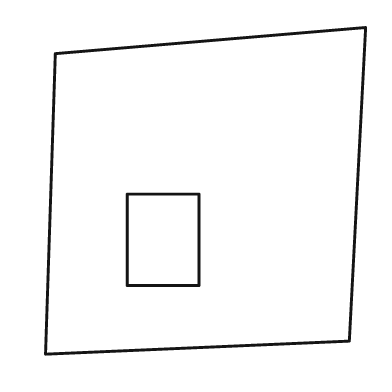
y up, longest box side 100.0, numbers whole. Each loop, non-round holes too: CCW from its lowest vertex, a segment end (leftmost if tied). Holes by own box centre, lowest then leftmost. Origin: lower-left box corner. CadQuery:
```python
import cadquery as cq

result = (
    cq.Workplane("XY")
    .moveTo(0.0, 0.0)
    .lineTo(93.0, 4.0)
    .lineTo(98.0, 100.0)
    .lineTo(3.0, 92.0)
    .close()
    .moveTo(25.0, 21.0)
    .lineTo(47.0, 21.0)
    .lineTo(47.0, 49.0)
    .lineTo(25.0, 49.0)
    .close()
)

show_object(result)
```